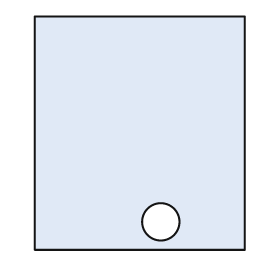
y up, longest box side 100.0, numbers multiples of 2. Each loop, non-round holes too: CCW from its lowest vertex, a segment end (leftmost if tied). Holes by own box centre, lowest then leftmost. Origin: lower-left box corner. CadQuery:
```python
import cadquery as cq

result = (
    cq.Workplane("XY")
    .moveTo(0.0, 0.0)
    .lineTo(90.0, 0.0)
    .lineTo(90.0, 100.0)
    .lineTo(0.0, 100.0)
    .close()
    .moveTo(54.0, 12.0)
    .circle(8.0)
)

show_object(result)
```